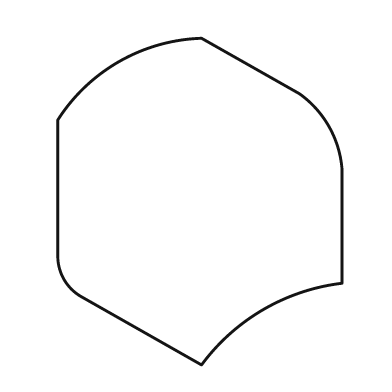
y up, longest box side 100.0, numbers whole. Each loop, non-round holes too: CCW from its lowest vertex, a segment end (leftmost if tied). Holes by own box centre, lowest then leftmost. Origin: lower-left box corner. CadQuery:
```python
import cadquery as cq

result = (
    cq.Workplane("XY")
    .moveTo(44.0, 0.0)
    .threePointArc((63.0, 17.0), (87.0, 25.0))
    .lineTo(87.0, 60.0)
    .threePointArc((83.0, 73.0), (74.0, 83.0))
    .lineTo(44.0, 100.0)
    .threePointArc((19.0, 93.0), (0.0, 75.0))
    .lineTo(0.0, 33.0)
    .threePointArc((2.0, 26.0), (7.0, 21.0))
    .close()
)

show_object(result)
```